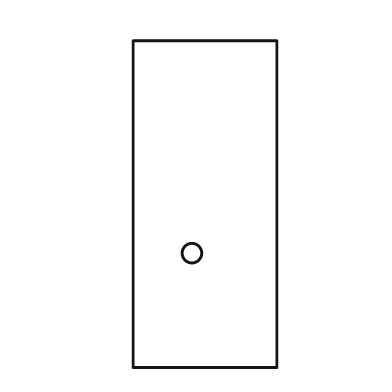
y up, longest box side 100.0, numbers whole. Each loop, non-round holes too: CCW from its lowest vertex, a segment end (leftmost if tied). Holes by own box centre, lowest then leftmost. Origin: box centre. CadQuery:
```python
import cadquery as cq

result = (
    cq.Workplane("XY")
    .moveTo(-22.0, -50.0)
    .lineTo(22.0, -50.0)
    .lineTo(22.0, 50.0)
    .lineTo(-22.0, 50.0)
    .close()
    .moveTo(-4.0, -15.0)
    .circle(3.0)
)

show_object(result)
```